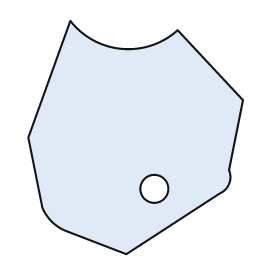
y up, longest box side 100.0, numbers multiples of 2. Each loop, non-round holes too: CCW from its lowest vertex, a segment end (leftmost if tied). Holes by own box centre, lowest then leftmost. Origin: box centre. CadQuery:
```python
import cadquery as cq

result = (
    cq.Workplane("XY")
    .moveTo(-4.0, -50.0)
    .lineTo(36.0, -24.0)
    .threePointArc((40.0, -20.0), (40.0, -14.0))
    .lineTo(46.0, 16.0)
    .lineTo(18.0, 46.0)
    .threePointArc((-6.0, 38.0), (-28.0, 50.0))
    .lineTo(-46.0, 0.0)
    .lineTo(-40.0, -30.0)
    .threePointArc((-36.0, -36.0), (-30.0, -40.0))
    .close()
    .moveTo(8.0, -22.0)
    .circle(6.0)
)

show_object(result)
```